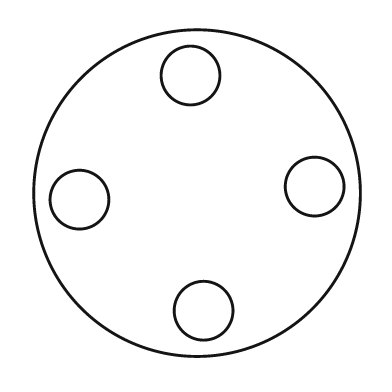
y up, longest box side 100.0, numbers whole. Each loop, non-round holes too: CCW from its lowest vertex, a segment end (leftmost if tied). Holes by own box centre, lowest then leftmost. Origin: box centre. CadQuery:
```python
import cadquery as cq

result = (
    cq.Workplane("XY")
    .moveTo(0.0, 0.0)
    .circle(50.0)
    .moveTo(2.0, -36.0)
    .circle(9.0)
    .moveTo(-36.0, -2.0)
    .circle(9.0)
    .moveTo(36.0, 2.0)
    .circle(9.0)
    .moveTo(-2.0, 36.0)
    .circle(9.0)
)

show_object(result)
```